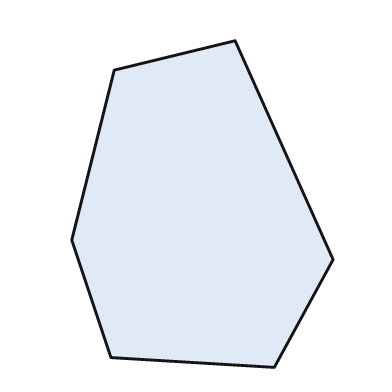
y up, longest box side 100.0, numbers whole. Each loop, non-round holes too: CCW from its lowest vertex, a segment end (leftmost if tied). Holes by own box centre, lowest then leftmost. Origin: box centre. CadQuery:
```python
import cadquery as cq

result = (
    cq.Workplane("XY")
    .moveTo(22.0, -50.0)
    .lineTo(40.0, -17.0)
    .lineTo(10.0, 50.0)
    .lineTo(-27.0, 41.0)
    .lineTo(-40.0, -11.0)
    .lineTo(-28.0, -47.0)
    .close()
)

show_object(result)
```